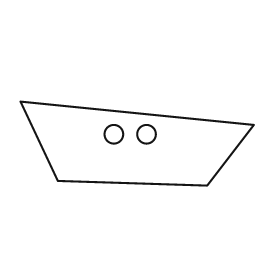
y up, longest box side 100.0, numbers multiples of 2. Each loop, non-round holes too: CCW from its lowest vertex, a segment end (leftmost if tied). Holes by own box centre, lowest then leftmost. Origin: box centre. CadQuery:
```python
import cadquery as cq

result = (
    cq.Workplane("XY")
    .moveTo(30.0, -18.0)
    .lineTo(50.0, 8.0)
    .lineTo(-50.0, 18.0)
    .lineTo(-34.0, -16.0)
    .close()
    .moveTo(-10.0, 4.0)
    .circle(4.0)
    .moveTo(4.0, 4.0)
    .circle(4.0)
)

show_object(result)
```